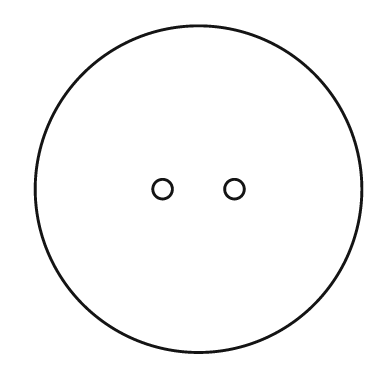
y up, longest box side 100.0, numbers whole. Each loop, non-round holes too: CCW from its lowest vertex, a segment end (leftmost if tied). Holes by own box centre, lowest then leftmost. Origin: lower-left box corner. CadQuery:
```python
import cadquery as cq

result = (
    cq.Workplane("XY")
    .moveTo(50.0, 50.0)
    .circle(50.0)
    .moveTo(39.0, 50.0)
    .circle(3.0)
    .moveTo(61.0, 50.0)
    .circle(3.0)
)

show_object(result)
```